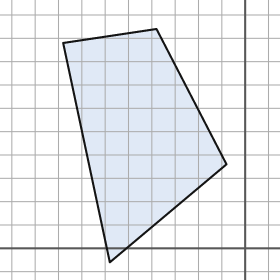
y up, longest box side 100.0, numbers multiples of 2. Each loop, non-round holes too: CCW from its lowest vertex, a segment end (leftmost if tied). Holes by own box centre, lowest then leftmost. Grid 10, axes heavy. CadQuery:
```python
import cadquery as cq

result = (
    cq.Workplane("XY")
    .moveTo(-58.0, -6.0)
    .lineTo(-8.0, 36.0)
    .lineTo(-38.0, 94.0)
    .lineTo(-78.0, 88.0)
    .close()
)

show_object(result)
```